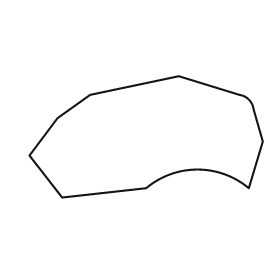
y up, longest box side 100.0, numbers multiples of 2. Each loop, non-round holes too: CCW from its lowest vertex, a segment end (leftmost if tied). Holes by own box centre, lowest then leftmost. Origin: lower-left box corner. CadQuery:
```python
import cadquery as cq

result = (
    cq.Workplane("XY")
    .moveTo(14.0, 0.0)
    .lineTo(50.0, 4.0)
    .threePointArc((72.0, 12.0), (94.0, 4.0))
    .lineTo(100.0, 24.0)
    .lineTo(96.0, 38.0)
    .threePointArc((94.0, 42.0), (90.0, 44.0))
    .lineTo(64.0, 52.0)
    .lineTo(26.0, 44.0)
    .lineTo(12.0, 34.0)
    .lineTo(0.0, 18.0)
    .close()
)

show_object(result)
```